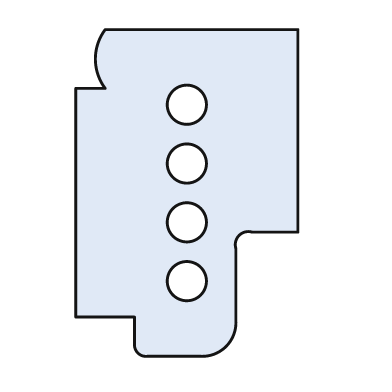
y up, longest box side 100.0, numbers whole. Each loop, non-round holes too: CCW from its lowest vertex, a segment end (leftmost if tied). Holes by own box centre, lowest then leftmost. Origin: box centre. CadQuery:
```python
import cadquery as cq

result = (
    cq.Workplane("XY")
    .moveTo(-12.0, -50.0)
    .lineTo(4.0, -50.0)
    .threePointArc((12.0, -47.0), (15.0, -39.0))
    .lineTo(15.0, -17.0)
    .threePointArc((16.0, -13.0), (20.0, -12.0))
    .lineTo(34.0, -12.0)
    .lineTo(34.0, 50.0)
    .lineTo(-25.0, 50.0)
    .threePointArc((-28.0, 41.0), (-25.0, 32.0))
    .lineTo(-34.0, 32.0)
    .lineTo(-34.0, -38.0)
    .lineTo(-16.0, -38.0)
    .lineTo(-16.0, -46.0)
    .threePointArc((-15.0, -49.0), (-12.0, -50.0))
    .close()
    .moveTo(0.0, -27.0)
    .circle(6.0)
    .moveTo(0.0, -9.0)
    .circle(6.0)
    .moveTo(0.0, 9.0)
    .circle(6.0)
    .moveTo(0.0, 27.0)
    .circle(6.0)
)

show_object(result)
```